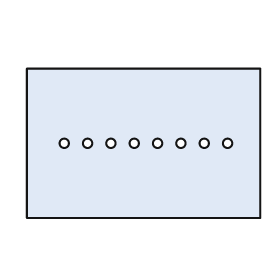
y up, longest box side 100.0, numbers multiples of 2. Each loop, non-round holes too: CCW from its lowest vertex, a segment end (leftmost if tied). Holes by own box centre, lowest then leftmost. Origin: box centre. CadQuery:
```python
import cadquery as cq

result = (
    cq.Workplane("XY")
    .moveTo(-50.0, -32.0)
    .lineTo(50.0, -32.0)
    .lineTo(50.0, 32.0)
    .lineTo(-50.0, 32.0)
    .close()
    .moveTo(-34.0, 0.0)
    .circle(2.0)
    .moveTo(-24.0, 0.0)
    .circle(2.0)
    .moveTo(-14.0, 0.0)
    .circle(2.0)
    .moveTo(-4.0, 0.0)
    .circle(2.0)
    .moveTo(6.0, 0.0)
    .circle(2.0)
    .moveTo(16.0, 0.0)
    .circle(2.0)
    .moveTo(26.0, 0.0)
    .circle(2.0)
    .moveTo(36.0, 0.0)
    .circle(2.0)
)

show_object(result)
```